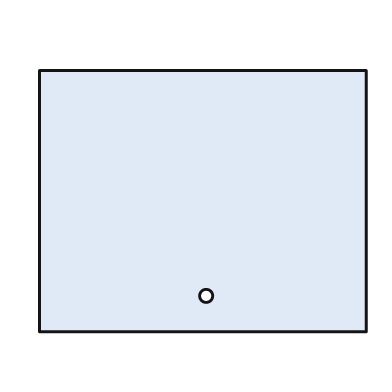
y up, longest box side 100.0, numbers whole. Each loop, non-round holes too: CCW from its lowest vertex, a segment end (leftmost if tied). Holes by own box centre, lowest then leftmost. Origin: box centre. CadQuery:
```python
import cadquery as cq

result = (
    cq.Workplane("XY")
    .moveTo(-50.0, -40.0)
    .lineTo(50.0, -40.0)
    .lineTo(50.0, 40.0)
    .lineTo(-50.0, 40.0)
    .close()
    .moveTo(1.0, -29.0)
    .circle(2.0)
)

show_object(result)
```